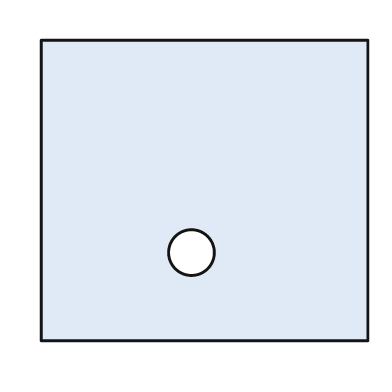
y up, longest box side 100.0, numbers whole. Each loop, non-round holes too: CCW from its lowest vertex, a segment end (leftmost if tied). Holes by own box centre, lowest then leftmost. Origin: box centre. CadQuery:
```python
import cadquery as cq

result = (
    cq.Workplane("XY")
    .moveTo(-50.0, -46.0)
    .lineTo(50.0, -46.0)
    .lineTo(50.0, 46.0)
    .lineTo(-50.0, 46.0)
    .close()
    .moveTo(-4.0, -19.0)
    .circle(7.0)
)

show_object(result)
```